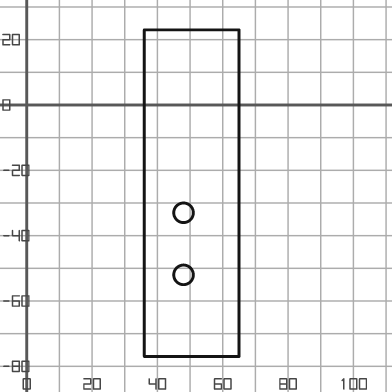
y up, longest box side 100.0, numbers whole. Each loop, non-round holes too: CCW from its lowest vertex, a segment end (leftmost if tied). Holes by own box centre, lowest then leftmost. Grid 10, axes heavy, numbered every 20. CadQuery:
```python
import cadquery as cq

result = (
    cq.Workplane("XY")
    .moveTo(36.0, -77.0)
    .lineTo(65.0, -77.0)
    .lineTo(65.0, 23.0)
    .lineTo(36.0, 23.0)
    .close()
    .moveTo(48.0, -52.0)
    .circle(3.0)
    .moveTo(48.0, -33.0)
    .circle(3.0)
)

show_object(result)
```